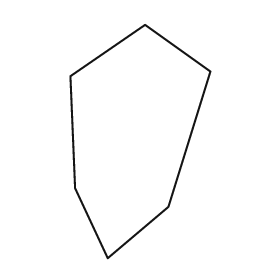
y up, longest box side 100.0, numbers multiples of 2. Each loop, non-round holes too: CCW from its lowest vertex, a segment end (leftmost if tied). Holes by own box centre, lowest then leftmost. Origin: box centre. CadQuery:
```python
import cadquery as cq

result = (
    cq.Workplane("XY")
    .moveTo(-14.0, -50.0)
    .lineTo(12.0, -28.0)
    .lineTo(30.0, 30.0)
    .lineTo(2.0, 50.0)
    .lineTo(-30.0, 28.0)
    .lineTo(-28.0, -20.0)
    .close()
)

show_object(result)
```